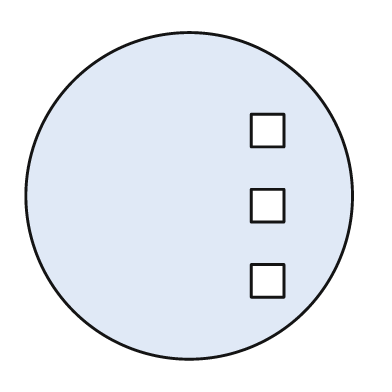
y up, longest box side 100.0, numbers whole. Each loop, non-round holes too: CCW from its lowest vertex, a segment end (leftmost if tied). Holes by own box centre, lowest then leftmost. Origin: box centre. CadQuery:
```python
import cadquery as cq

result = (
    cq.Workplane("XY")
    .moveTo(0.0, 0.0)
    .circle(50.0)
    .moveTo(19.0, -31.0)
    .lineTo(29.0, -31.0)
    .lineTo(29.0, -21.0)
    .lineTo(19.0, -21.0)
    .close()
    .moveTo(19.0, -8.0)
    .lineTo(29.0, -8.0)
    .lineTo(29.0, 2.0)
    .lineTo(19.0, 2.0)
    .close()
    .moveTo(19.0, 15.0)
    .lineTo(29.0, 15.0)
    .lineTo(29.0, 25.0)
    .lineTo(19.0, 25.0)
    .close()
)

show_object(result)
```